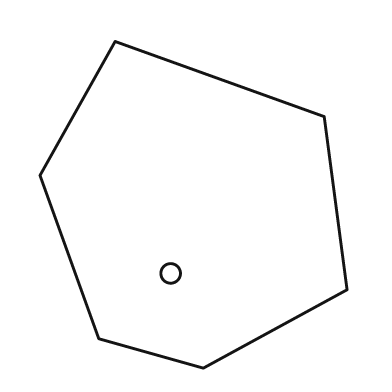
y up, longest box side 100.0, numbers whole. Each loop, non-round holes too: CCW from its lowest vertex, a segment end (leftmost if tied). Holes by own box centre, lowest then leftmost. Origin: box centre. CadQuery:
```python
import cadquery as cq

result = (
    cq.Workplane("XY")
    .moveTo(3.0, -50.0)
    .lineTo(47.0, -26.0)
    .lineTo(40.0, 27.0)
    .lineTo(-24.0, 50.0)
    .lineTo(-47.0, 9.0)
    .lineTo(-29.0, -41.0)
    .close()
    .moveTo(-7.0, -21.0)
    .circle(3.0)
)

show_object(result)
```